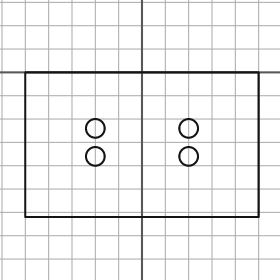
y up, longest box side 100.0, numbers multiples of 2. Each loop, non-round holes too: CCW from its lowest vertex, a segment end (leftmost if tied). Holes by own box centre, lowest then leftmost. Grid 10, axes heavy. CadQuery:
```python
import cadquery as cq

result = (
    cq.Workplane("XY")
    .moveTo(-50.0, -62.0)
    .lineTo(50.0, -62.0)
    .lineTo(50.0, 0.0)
    .lineTo(-50.0, 0.0)
    .close()
    .moveTo(-20.0, -36.0)
    .circle(4.0)
    .moveTo(20.0, -36.0)
    .circle(4.0)
    .moveTo(-20.0, -24.0)
    .circle(4.0)
    .moveTo(20.0, -24.0)
    .circle(4.0)
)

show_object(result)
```